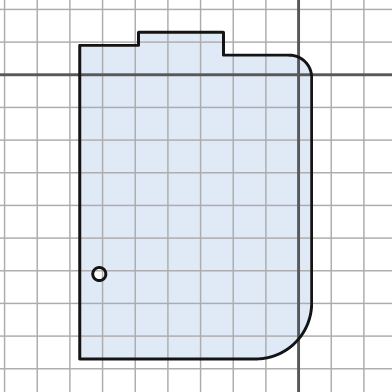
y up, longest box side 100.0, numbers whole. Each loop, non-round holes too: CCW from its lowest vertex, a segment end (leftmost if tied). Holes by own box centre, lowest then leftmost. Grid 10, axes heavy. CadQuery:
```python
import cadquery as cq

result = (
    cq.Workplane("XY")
    .moveTo(-67.0, -87.0)
    .lineTo(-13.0, -87.0)
    .threePointArc((-1.0, -82.0), (4.0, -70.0))
    .lineTo(4.0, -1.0)
    .threePointArc((2.0, 4.0), (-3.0, 6.0))
    .lineTo(-23.0, 6.0)
    .lineTo(-23.0, 13.0)
    .lineTo(-49.0, 13.0)
    .lineTo(-49.0, 9.0)
    .lineTo(-67.0, 9.0)
    .close()
    .moveTo(-61.0, -61.0)
    .circle(2.0)
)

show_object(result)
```